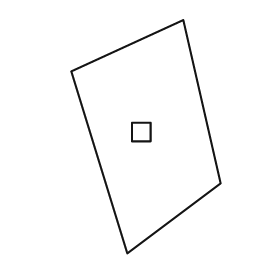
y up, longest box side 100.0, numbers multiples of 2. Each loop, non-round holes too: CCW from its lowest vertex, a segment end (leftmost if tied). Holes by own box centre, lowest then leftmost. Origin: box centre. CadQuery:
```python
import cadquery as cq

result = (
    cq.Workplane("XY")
    .moveTo(-8.0, -50.0)
    .lineTo(32.0, -20.0)
    .lineTo(16.0, 50.0)
    .lineTo(-32.0, 28.0)
    .close()
    .moveTo(-6.0, -2.0)
    .lineTo(2.0, -2.0)
    .lineTo(2.0, 6.0)
    .lineTo(-6.0, 6.0)
    .close()
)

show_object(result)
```